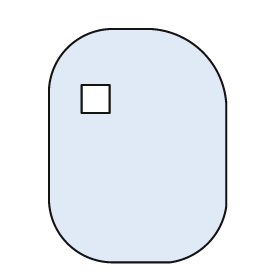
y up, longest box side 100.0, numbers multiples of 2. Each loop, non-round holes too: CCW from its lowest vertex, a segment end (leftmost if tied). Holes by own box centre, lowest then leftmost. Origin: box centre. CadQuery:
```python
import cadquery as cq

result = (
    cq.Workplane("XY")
    .moveTo(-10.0, -50.0)
    .lineTo(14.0, -50.0)
    .threePointArc((30.0, -42.0), (38.0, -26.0))
    .lineTo(38.0, 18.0)
    .threePointArc((28.0, 40.0), (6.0, 50.0))
    .lineTo(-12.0, 50.0)
    .threePointArc((-30.0, 42.0), (-38.0, 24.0))
    .lineTo(-38.0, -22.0)
    .threePointArc((-30.0, -42.0), (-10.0, -50.0))
    .close()
    .moveTo(-24.0, 14.0)
    .lineTo(-12.0, 14.0)
    .lineTo(-12.0, 26.0)
    .lineTo(-24.0, 26.0)
    .close()
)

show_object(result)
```